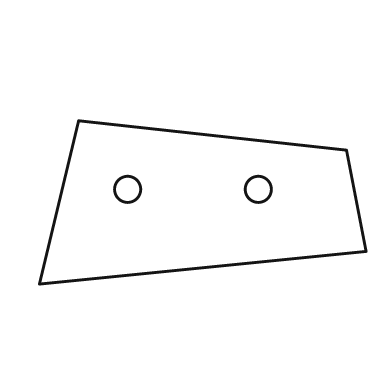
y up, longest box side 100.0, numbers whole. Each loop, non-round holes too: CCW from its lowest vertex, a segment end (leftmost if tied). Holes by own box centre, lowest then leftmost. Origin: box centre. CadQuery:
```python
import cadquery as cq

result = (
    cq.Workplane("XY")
    .moveTo(-50.0, -25.0)
    .lineTo(50.0, -15.0)
    .lineTo(44.0, 16.0)
    .lineTo(-38.0, 25.0)
    .close()
    .moveTo(-23.0, 4.0)
    .circle(4.0)
    .moveTo(17.0, 4.0)
    .circle(4.0)
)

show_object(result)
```